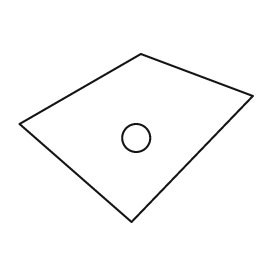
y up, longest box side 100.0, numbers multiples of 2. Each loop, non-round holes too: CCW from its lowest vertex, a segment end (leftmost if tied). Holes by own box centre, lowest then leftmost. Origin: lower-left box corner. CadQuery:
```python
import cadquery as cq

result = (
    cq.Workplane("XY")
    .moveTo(48.0, 0.0)
    .lineTo(100.0, 54.0)
    .lineTo(52.0, 72.0)
    .lineTo(0.0, 42.0)
    .close()
    .moveTo(50.0, 36.0)
    .circle(6.0)
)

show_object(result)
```